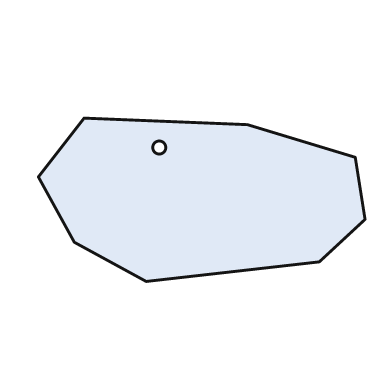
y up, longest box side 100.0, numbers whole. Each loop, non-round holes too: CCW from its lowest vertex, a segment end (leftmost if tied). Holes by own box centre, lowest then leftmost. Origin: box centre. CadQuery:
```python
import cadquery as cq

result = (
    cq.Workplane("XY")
    .moveTo(-17.0, -25.0)
    .lineTo(36.0, -19.0)
    .lineTo(50.0, -6.0)
    .lineTo(47.0, 13.0)
    .lineTo(14.0, 23.0)
    .lineTo(-36.0, 25.0)
    .lineTo(-50.0, 7.0)
    .lineTo(-39.0, -13.0)
    .close()
    .moveTo(-13.0, 16.0)
    .circle(2.0)
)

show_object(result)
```